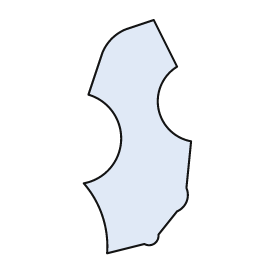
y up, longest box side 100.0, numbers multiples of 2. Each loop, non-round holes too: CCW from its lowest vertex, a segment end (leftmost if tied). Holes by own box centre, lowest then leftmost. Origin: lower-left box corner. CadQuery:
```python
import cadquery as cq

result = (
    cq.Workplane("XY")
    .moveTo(10.0, 0.0)
    .lineTo(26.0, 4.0)
    .threePointArc((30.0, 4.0), (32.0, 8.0))
    .lineTo(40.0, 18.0)
    .threePointArc((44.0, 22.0), (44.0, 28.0))
    .lineTo(46.0, 48.0)
    .threePointArc((32.0, 62.0), (40.0, 80.0))
    .lineTo(30.0, 100.0)
    .lineTo(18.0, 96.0)
    .threePointArc((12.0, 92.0), (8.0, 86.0))
    .lineTo(2.0, 68.0)
    .threePointArc((16.0, 48.0), (0.0, 30.0))
    .threePointArc((8.0, 16.0), (10.0, 0.0))
    .close()
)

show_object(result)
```